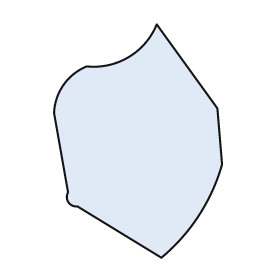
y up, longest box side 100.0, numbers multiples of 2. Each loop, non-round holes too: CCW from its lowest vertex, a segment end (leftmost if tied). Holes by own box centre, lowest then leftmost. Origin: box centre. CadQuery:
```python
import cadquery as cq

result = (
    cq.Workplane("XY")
    .moveTo(10.0, -50.0)
    .threePointArc((26.0, -32.0), (36.0, -10.0))
    .lineTo(34.0, 14.0)
    .lineTo(8.0, 50.0)
    .threePointArc((-4.0, 36.0), (-22.0, 32.0))
    .threePointArc((-32.0, 24.0), (-36.0, 12.0))
    .lineTo(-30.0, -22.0)
    .threePointArc((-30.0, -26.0), (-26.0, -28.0))
    .close()
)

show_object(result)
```